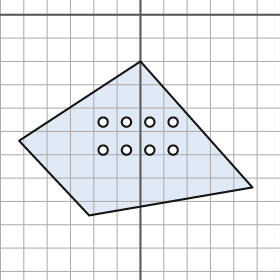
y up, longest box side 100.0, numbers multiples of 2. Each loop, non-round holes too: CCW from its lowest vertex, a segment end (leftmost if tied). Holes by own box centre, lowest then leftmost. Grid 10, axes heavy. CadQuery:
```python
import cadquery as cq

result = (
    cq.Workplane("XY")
    .moveTo(-22.0, -86.0)
    .lineTo(48.0, -74.0)
    .lineTo(0.0, -20.0)
    .lineTo(-52.0, -54.0)
    .close()
    .moveTo(-16.0, -58.0)
    .circle(2.0)
    .moveTo(-6.0, -58.0)
    .circle(2.0)
    .moveTo(4.0, -58.0)
    .circle(2.0)
    .moveTo(14.0, -58.0)
    .circle(2.0)
    .moveTo(-16.0, -46.0)
    .circle(2.0)
    .moveTo(-6.0, -46.0)
    .circle(2.0)
    .moveTo(4.0, -46.0)
    .circle(2.0)
    .moveTo(14.0, -46.0)
    .circle(2.0)
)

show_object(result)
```